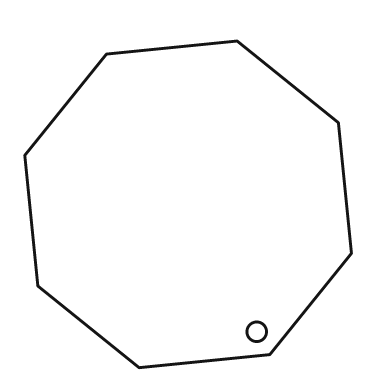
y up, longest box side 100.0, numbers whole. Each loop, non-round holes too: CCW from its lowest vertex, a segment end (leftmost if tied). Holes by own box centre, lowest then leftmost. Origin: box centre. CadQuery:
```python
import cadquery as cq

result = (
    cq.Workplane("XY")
    .moveTo(-15.0, -50.0)
    .lineTo(25.0, -46.0)
    .lineTo(50.0, -15.0)
    .lineTo(46.0, 25.0)
    .lineTo(15.0, 50.0)
    .lineTo(-25.0, 46.0)
    .lineTo(-50.0, 15.0)
    .lineTo(-46.0, -25.0)
    .close()
    .moveTo(21.0, -39.0)
    .circle(3.0)
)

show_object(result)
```